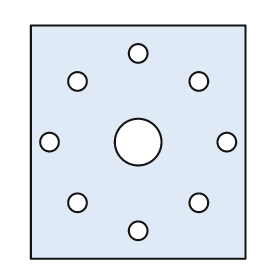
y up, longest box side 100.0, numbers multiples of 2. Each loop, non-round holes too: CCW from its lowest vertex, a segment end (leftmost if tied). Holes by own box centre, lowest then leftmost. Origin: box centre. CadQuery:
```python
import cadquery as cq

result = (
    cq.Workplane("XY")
    .moveTo(-46.0, -50.0)
    .lineTo(46.0, -50.0)
    .lineTo(46.0, 50.0)
    .lineTo(-46.0, 50.0)
    .close()
    .moveTo(0.0, -38.0)
    .circle(4.0)
    .moveTo(-26.0, -26.0)
    .circle(4.0)
    .moveTo(26.0, -26.0)
    .circle(4.0)
    .moveTo(-38.0, 0.0)
    .circle(4.0)
    .moveTo(0.0, 0.0)
    .circle(10.0)
    .moveTo(38.0, 0.0)
    .circle(4.0)
    .moveTo(-26.0, 26.0)
    .circle(4.0)
    .moveTo(26.0, 26.0)
    .circle(4.0)
    .moveTo(0.0, 38.0)
    .circle(4.0)
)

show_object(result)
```